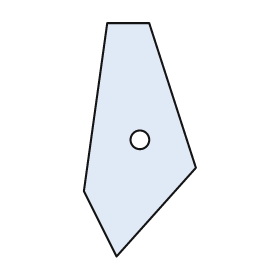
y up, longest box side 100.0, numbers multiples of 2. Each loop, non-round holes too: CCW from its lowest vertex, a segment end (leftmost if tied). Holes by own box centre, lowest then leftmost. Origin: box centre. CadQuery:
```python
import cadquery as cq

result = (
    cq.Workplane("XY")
    .moveTo(-10.0, -50.0)
    .lineTo(24.0, -12.0)
    .lineTo(4.0, 50.0)
    .lineTo(-14.0, 50.0)
    .lineTo(-24.0, -22.0)
    .close()
    .moveTo(0.0, 0.0)
    .circle(4.0)
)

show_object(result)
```